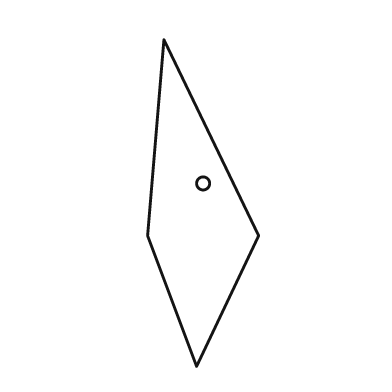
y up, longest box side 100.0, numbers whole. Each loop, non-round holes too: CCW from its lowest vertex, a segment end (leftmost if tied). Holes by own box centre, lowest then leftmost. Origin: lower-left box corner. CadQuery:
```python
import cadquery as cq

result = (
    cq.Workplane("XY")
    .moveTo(15.0, 0.0)
    .lineTo(34.0, 40.0)
    .lineTo(5.0, 100.0)
    .lineTo(0.0, 40.0)
    .close()
    .moveTo(17.0, 56.0)
    .circle(2.0)
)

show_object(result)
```